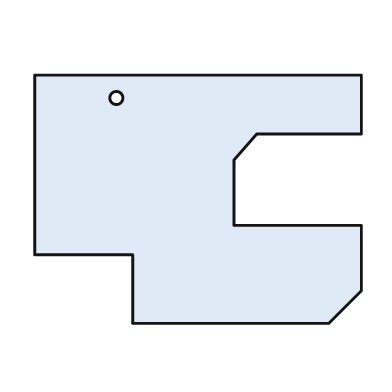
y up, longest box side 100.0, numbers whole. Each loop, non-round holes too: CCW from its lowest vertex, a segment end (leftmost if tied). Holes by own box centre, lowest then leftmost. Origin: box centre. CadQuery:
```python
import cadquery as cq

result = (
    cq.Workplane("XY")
    .moveTo(-20.0, -38.0)
    .lineTo(40.0, -38.0)
    .lineTo(50.0, -28.0)
    .lineTo(50.0, -8.0)
    .lineTo(11.0, -8.0)
    .lineTo(11.0, 12.0)
    .lineTo(18.0, 20.0)
    .lineTo(50.0, 20.0)
    .lineTo(50.0, 38.0)
    .lineTo(-50.0, 38.0)
    .lineTo(-50.0, -17.0)
    .lineTo(-20.0, -17.0)
    .close()
    .moveTo(-25.0, 31.0)
    .circle(2.0)
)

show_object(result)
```